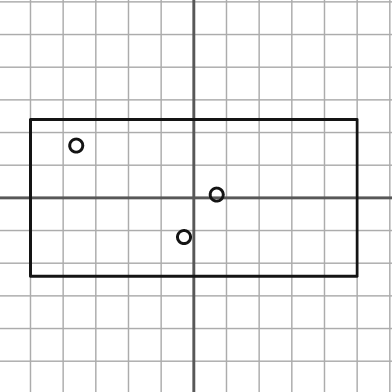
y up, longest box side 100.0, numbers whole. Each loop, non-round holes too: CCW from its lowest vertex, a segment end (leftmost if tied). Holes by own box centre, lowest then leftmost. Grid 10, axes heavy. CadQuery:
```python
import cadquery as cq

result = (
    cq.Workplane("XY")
    .moveTo(-50.0, -24.0)
    .lineTo(50.0, -24.0)
    .lineTo(50.0, 24.0)
    .lineTo(-50.0, 24.0)
    .close()
    .moveTo(-3.0, -12.0)
    .circle(2.0)
    .moveTo(7.0, 1.0)
    .circle(2.0)
    .moveTo(-36.0, 16.0)
    .circle(2.0)
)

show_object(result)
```